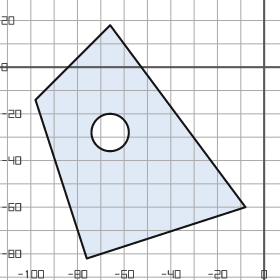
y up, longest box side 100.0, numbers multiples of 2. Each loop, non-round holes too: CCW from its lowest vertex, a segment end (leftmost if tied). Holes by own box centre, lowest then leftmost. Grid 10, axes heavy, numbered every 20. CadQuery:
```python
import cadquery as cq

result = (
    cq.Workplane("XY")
    .moveTo(-76.0, -82.0)
    .lineTo(-8.0, -60.0)
    .lineTo(-66.0, 18.0)
    .lineTo(-98.0, -14.0)
    .close()
    .moveTo(-66.0, -28.0)
    .circle(8.0)
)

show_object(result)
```